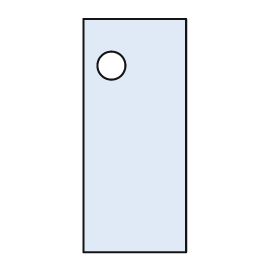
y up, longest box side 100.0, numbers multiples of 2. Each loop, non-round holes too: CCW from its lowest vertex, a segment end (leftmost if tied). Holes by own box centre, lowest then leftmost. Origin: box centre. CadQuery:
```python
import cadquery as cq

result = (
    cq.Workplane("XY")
    .moveTo(-22.0, -50.0)
    .lineTo(22.0, -50.0)
    .lineTo(22.0, 50.0)
    .lineTo(-22.0, 50.0)
    .close()
    .moveTo(-10.0, 30.0)
    .circle(6.0)
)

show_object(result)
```